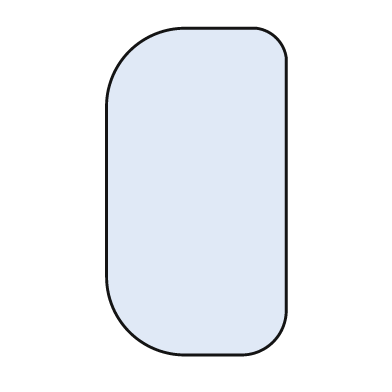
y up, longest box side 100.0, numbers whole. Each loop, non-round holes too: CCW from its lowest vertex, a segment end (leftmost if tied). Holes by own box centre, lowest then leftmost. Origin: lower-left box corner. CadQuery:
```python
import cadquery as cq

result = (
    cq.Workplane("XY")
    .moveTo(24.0, 0.0)
    .lineTo(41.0, 0.0)
    .threePointArc((51.0, 4.0), (55.0, 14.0))
    .lineTo(55.0, 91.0)
    .threePointArc((52.0, 97.0), (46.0, 100.0))
    .lineTo(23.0, 100.0)
    .threePointArc((7.0, 93.0), (0.0, 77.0))
    .lineTo(0.0, 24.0)
    .threePointArc((7.0, 7.0), (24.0, 0.0))
    .close()
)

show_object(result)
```